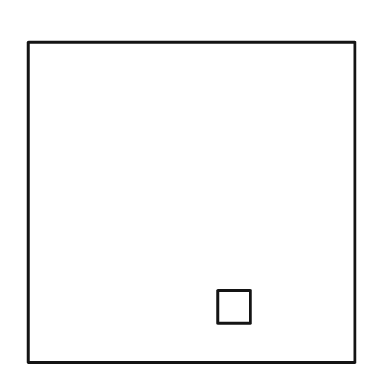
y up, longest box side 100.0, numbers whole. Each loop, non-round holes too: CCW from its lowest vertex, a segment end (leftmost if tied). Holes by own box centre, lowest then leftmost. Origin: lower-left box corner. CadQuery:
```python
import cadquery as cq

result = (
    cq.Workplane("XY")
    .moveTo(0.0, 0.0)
    .lineTo(100.0, 0.0)
    .lineTo(100.0, 98.0)
    .lineTo(0.0, 98.0)
    .close()
    .moveTo(58.0, 12.0)
    .lineTo(68.0, 12.0)
    .lineTo(68.0, 22.0)
    .lineTo(58.0, 22.0)
    .close()
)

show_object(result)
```